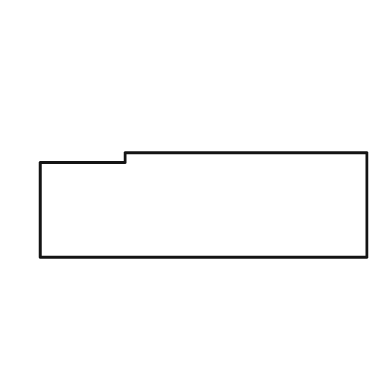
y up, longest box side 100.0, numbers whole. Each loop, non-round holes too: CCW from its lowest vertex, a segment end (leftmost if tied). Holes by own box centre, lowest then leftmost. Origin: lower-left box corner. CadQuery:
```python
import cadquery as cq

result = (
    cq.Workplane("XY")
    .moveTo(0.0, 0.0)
    .lineTo(100.0, 0.0)
    .lineTo(100.0, 32.0)
    .lineTo(26.0, 32.0)
    .lineTo(26.0, 29.0)
    .lineTo(0.0, 29.0)
    .close()
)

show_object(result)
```